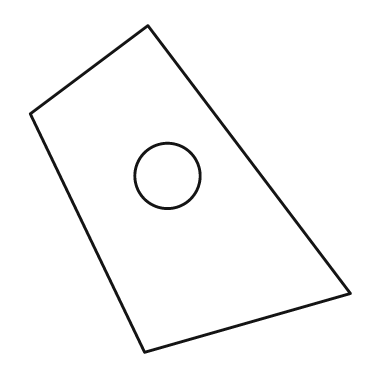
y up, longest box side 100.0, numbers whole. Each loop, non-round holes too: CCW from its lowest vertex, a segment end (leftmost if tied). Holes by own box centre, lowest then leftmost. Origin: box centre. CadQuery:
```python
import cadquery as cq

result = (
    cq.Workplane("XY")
    .moveTo(-14.0, -50.0)
    .lineTo(49.0, -32.0)
    .lineTo(-13.0, 50.0)
    .lineTo(-49.0, 23.0)
    .close()
    .moveTo(-7.0, 4.0)
    .circle(10.0)
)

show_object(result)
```